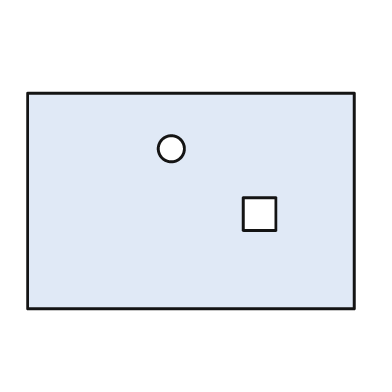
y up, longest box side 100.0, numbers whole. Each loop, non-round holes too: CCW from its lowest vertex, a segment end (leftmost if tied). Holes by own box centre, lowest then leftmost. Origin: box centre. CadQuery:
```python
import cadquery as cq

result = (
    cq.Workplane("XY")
    .moveTo(-50.0, -33.0)
    .lineTo(50.0, -33.0)
    .lineTo(50.0, 33.0)
    .lineTo(-50.0, 33.0)
    .close()
    .moveTo(16.0, -9.0)
    .lineTo(26.0, -9.0)
    .lineTo(26.0, 1.0)
    .lineTo(16.0, 1.0)
    .close()
    .moveTo(-6.0, 16.0)
    .circle(4.0)
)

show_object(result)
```